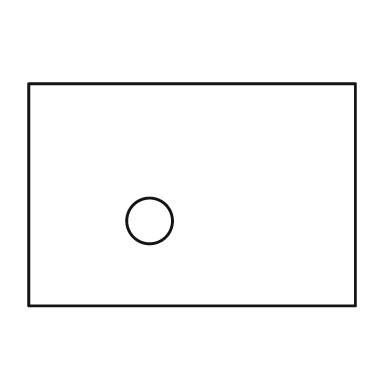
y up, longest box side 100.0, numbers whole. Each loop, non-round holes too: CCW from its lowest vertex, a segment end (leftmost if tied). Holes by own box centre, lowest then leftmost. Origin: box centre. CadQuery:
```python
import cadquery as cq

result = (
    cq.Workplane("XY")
    .moveTo(-50.0, -34.0)
    .lineTo(50.0, -34.0)
    .lineTo(50.0, 34.0)
    .lineTo(-50.0, 34.0)
    .close()
    .moveTo(-13.0, -8.0)
    .circle(7.0)
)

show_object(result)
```